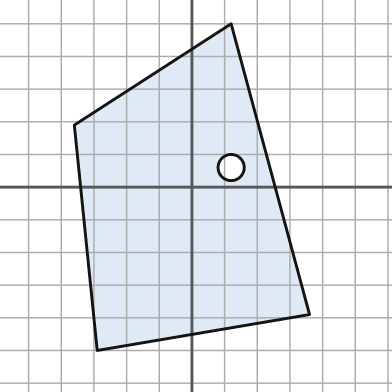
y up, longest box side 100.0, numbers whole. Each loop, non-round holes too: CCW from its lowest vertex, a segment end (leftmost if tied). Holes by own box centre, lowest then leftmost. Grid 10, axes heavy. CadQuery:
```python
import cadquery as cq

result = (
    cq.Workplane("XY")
    .moveTo(-29.0, -50.0)
    .lineTo(36.0, -39.0)
    .lineTo(12.0, 50.0)
    .lineTo(-36.0, 19.0)
    .close()
    .moveTo(12.0, 6.0)
    .circle(4.0)
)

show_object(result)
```